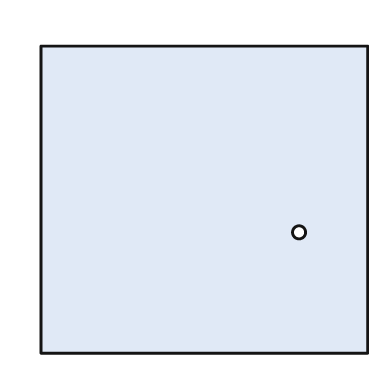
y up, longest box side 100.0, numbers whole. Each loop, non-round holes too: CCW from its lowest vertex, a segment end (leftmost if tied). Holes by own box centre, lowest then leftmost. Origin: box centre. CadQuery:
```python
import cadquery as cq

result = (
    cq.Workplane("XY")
    .moveTo(-50.0, -47.0)
    .lineTo(50.0, -47.0)
    .lineTo(50.0, 47.0)
    .lineTo(-50.0, 47.0)
    .close()
    .moveTo(29.0, -10.0)
    .circle(2.0)
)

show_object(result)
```